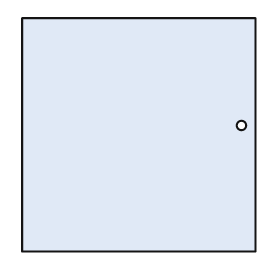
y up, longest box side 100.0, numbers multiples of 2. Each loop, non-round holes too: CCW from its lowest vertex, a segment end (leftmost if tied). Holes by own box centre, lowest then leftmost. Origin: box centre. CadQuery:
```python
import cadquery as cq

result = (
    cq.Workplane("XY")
    .moveTo(-50.0, -50.0)
    .lineTo(50.0, -50.0)
    .lineTo(50.0, 50.0)
    .lineTo(-50.0, 50.0)
    .close()
    .moveTo(44.0, 4.0)
    .circle(2.0)
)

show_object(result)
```